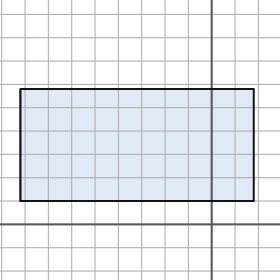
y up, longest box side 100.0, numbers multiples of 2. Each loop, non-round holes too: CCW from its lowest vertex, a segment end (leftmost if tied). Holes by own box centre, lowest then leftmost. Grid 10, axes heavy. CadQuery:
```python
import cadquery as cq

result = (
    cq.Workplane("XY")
    .moveTo(-82.0, 10.0)
    .lineTo(18.0, 10.0)
    .lineTo(18.0, 58.0)
    .lineTo(-82.0, 58.0)
    .close()
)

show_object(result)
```